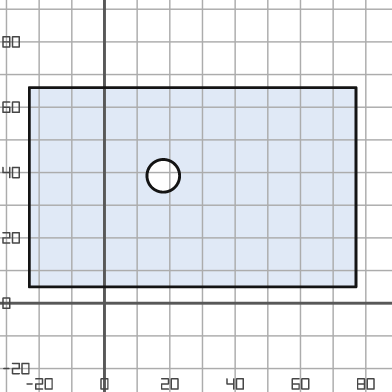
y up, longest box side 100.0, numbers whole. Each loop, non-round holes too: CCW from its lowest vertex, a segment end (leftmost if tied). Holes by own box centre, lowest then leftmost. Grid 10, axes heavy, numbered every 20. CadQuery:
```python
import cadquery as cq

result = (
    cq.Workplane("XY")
    .moveTo(-23.0, 5.0)
    .lineTo(77.0, 5.0)
    .lineTo(77.0, 66.0)
    .lineTo(-23.0, 66.0)
    .close()
    .moveTo(18.0, 39.0)
    .circle(5.0)
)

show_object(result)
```